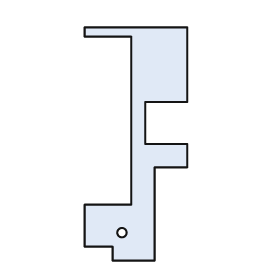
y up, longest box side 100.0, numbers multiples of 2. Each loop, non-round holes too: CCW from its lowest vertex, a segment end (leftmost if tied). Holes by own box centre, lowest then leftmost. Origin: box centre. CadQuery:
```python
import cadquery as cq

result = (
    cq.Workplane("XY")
    .moveTo(-10.0, -50.0)
    .lineTo(8.0, -50.0)
    .lineTo(8.0, -10.0)
    .lineTo(22.0, -10.0)
    .lineTo(22.0, 0.0)
    .lineTo(4.0, 0.0)
    .lineTo(4.0, 18.0)
    .lineTo(22.0, 18.0)
    .lineTo(22.0, 50.0)
    .lineTo(-22.0, 50.0)
    .lineTo(-22.0, 46.0)
    .lineTo(-2.0, 46.0)
    .lineTo(-2.0, -26.0)
    .lineTo(-22.0, -26.0)
    .lineTo(-22.0, -44.0)
    .lineTo(-10.0, -44.0)
    .close()
    .moveTo(-6.0, -38.0)
    .circle(2.0)
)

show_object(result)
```